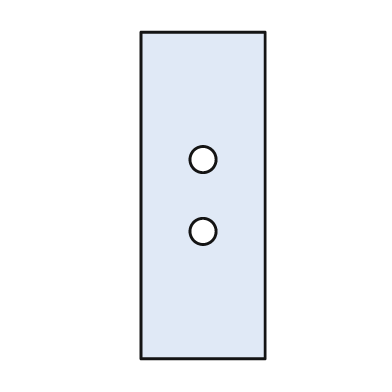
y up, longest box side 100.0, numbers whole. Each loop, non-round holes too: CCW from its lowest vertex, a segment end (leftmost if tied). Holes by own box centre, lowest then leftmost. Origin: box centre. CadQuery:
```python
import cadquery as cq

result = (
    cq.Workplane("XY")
    .moveTo(-19.0, -50.0)
    .lineTo(19.0, -50.0)
    .lineTo(19.0, 50.0)
    .lineTo(-19.0, 50.0)
    .close()
    .moveTo(0.0, -11.0)
    .circle(4.0)
    .moveTo(0.0, 11.0)
    .circle(4.0)
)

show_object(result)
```